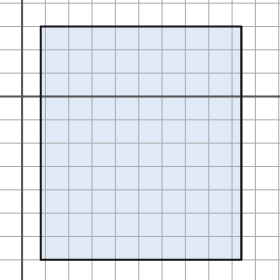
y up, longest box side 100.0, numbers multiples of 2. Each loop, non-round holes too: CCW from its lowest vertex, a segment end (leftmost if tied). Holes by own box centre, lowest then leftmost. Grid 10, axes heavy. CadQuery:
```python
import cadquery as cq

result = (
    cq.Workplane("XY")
    .moveTo(8.0, -70.0)
    .lineTo(94.0, -70.0)
    .lineTo(94.0, 30.0)
    .lineTo(8.0, 30.0)
    .close()
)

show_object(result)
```